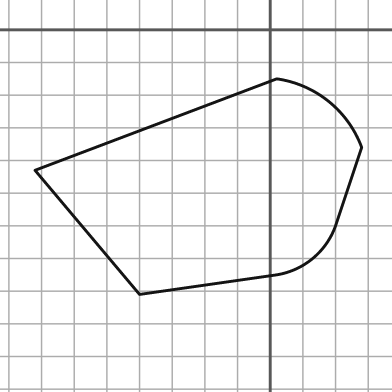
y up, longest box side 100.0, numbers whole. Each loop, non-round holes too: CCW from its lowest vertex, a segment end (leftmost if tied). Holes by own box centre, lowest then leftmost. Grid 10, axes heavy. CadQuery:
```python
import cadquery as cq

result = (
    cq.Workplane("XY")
    .moveTo(-40.0, -81.0)
    .lineTo(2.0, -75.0)
    .threePointArc((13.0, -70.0), (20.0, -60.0))
    .lineTo(28.0, -36.0)
    .threePointArc((18.0, -22.0), (2.0, -15.0))
    .lineTo(-72.0, -43.0)
    .close()
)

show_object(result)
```